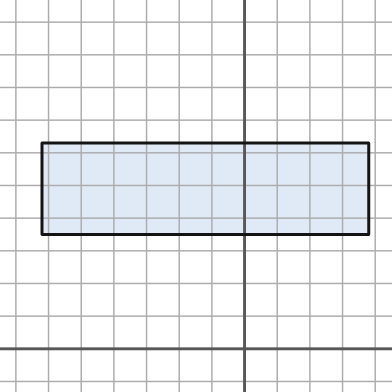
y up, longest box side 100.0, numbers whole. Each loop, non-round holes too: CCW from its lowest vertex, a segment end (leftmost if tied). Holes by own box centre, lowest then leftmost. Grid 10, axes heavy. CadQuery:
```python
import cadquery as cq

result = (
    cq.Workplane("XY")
    .moveTo(-62.0, 35.0)
    .lineTo(38.0, 35.0)
    .lineTo(38.0, 63.0)
    .lineTo(-62.0, 63.0)
    .close()
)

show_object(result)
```